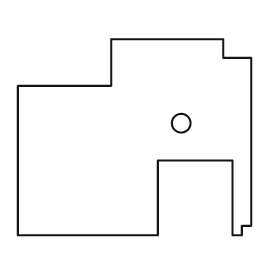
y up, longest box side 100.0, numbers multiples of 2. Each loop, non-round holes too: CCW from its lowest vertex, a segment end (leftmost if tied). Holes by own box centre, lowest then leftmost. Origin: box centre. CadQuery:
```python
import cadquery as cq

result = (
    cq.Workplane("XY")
    .moveTo(-50.0, -42.0)
    .lineTo(10.0, -42.0)
    .lineTo(10.0, -10.0)
    .lineTo(42.0, -10.0)
    .lineTo(42.0, -42.0)
    .lineTo(46.0, -42.0)
    .lineTo(46.0, -38.0)
    .lineTo(50.0, -38.0)
    .lineTo(50.0, 34.0)
    .lineTo(38.0, 34.0)
    .lineTo(38.0, 42.0)
    .lineTo(-10.0, 42.0)
    .lineTo(-10.0, 22.0)
    .lineTo(-50.0, 22.0)
    .close()
    .moveTo(20.0, 6.0)
    .circle(4.0)
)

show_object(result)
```